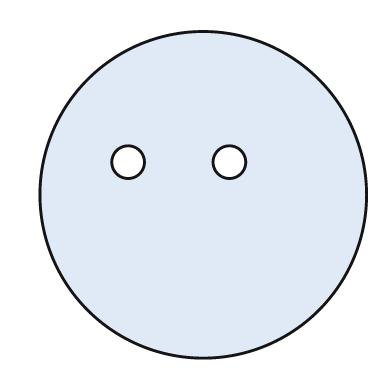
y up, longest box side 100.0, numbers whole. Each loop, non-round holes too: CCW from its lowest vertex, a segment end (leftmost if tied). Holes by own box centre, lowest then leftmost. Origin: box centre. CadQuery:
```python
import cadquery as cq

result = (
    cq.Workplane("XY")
    .moveTo(0.0, 0.0)
    .circle(50.0)
    .moveTo(-23.0, 10.0)
    .circle(5.0)
    .moveTo(8.0, 10.0)
    .circle(5.0)
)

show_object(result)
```